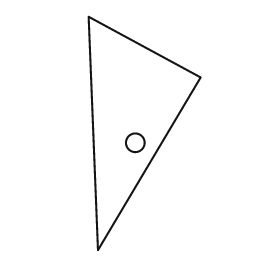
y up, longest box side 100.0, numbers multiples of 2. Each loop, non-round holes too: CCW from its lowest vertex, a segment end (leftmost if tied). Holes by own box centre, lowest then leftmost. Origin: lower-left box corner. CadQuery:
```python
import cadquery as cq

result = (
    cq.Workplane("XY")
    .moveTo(4.0, 0.0)
    .lineTo(48.0, 74.0)
    .lineTo(0.0, 100.0)
    .close()
    .moveTo(20.0, 46.0)
    .circle(4.0)
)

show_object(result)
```